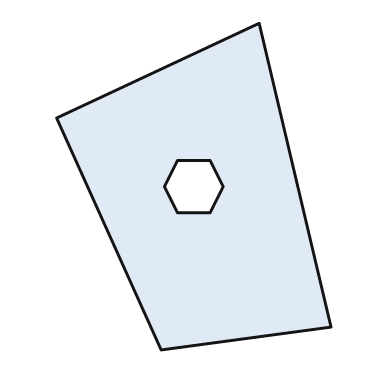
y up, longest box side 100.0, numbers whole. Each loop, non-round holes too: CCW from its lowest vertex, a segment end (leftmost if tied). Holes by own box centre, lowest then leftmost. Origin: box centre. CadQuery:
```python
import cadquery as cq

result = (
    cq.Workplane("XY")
    .moveTo(-10.0, -50.0)
    .lineTo(42.0, -43.0)
    .lineTo(20.0, 50.0)
    .lineTo(-42.0, 21.0)
    .close()
    .moveTo(-5.0, -8.0)
    .lineTo(5.0, -8.0)
    .lineTo(9.0, 0.0)
    .lineTo(5.0, 8.0)
    .lineTo(-5.0, 8.0)
    .lineTo(-9.0, 0.0)
    .close()
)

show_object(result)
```